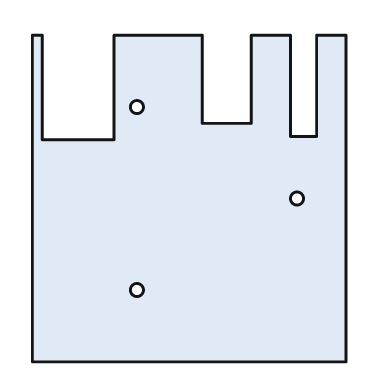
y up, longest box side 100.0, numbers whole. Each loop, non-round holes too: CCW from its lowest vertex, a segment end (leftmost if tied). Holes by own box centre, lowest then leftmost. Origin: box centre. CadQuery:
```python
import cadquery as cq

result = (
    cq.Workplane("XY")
    .moveTo(-48.0, -50.0)
    .lineTo(48.0, -50.0)
    .lineTo(48.0, 50.0)
    .lineTo(39.0, 50.0)
    .lineTo(39.0, 19.0)
    .lineTo(31.0, 19.0)
    .lineTo(31.0, 50.0)
    .lineTo(19.0, 50.0)
    .lineTo(19.0, 23.0)
    .lineTo(4.0, 23.0)
    .lineTo(4.0, 50.0)
    .lineTo(-23.0, 50.0)
    .lineTo(-23.0, 18.0)
    .lineTo(-45.0, 18.0)
    .lineTo(-45.0, 50.0)
    .lineTo(-48.0, 50.0)
    .close()
    .moveTo(-16.0, -28.0)
    .circle(2.0)
    .moveTo(33.0, 0.0)
    .circle(2.0)
    .moveTo(-16.0, 28.0)
    .circle(2.0)
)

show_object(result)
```